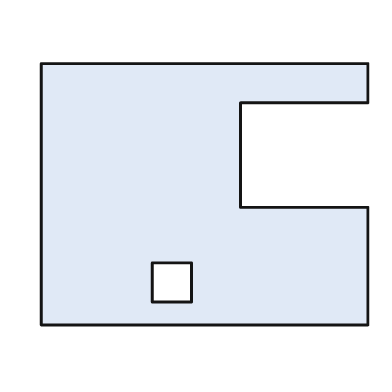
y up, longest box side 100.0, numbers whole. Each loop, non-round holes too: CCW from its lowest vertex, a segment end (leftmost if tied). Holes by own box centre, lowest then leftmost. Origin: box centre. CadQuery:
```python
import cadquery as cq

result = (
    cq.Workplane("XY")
    .moveTo(-50.0, -40.0)
    .lineTo(50.0, -40.0)
    .lineTo(50.0, -4.0)
    .lineTo(11.0, -4.0)
    .lineTo(11.0, 28.0)
    .lineTo(50.0, 28.0)
    .lineTo(50.0, 40.0)
    .lineTo(-50.0, 40.0)
    .close()
    .moveTo(-16.0, -33.0)
    .lineTo(-4.0, -33.0)
    .lineTo(-4.0, -21.0)
    .lineTo(-16.0, -21.0)
    .close()
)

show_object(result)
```